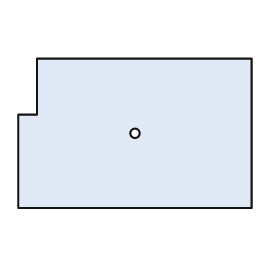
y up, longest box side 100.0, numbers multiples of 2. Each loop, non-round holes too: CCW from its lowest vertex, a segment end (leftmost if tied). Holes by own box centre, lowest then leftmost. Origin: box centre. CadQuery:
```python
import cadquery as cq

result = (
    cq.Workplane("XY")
    .moveTo(-50.0, -32.0)
    .lineTo(50.0, -32.0)
    .lineTo(50.0, 32.0)
    .lineTo(-42.0, 32.0)
    .lineTo(-42.0, 8.0)
    .lineTo(-50.0, 8.0)
    .close()
    .moveTo(0.0, 0.0)
    .circle(2.0)
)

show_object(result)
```